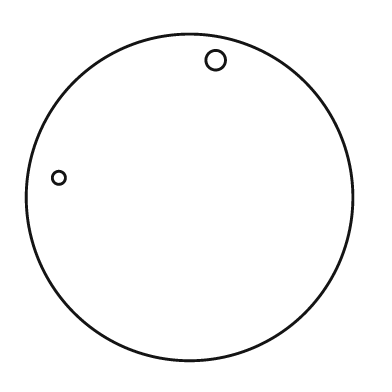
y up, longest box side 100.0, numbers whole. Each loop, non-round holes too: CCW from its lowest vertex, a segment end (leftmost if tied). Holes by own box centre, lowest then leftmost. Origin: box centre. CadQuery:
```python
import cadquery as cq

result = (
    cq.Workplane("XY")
    .moveTo(0.0, 0.0)
    .circle(50.0)
    .moveTo(-40.0, 6.0)
    .circle(2.0)
    .moveTo(8.0, 42.0)
    .circle(3.0)
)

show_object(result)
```